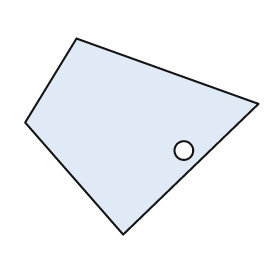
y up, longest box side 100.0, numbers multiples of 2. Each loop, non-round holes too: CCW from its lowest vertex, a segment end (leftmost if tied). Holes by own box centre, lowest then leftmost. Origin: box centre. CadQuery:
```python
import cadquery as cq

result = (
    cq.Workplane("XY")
    .moveTo(-8.0, -42.0)
    .lineTo(50.0, 14.0)
    .lineTo(-28.0, 42.0)
    .lineTo(-50.0, 6.0)
    .close()
    .moveTo(18.0, -6.0)
    .circle(4.0)
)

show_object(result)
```